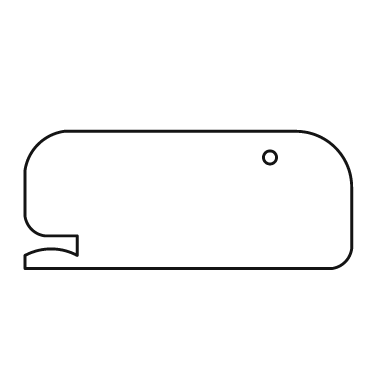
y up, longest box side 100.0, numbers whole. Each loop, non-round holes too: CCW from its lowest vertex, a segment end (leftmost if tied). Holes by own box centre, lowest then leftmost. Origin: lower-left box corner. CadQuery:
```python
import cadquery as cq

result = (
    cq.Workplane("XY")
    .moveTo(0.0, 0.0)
    .lineTo(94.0, 0.0)
    .threePointArc((98.0, 2.0), (100.0, 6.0))
    .lineTo(100.0, 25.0)
    .threePointArc((95.0, 37.0), (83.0, 42.0))
    .lineTo(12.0, 42.0)
    .threePointArc((4.0, 38.0), (0.0, 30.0))
    .lineTo(0.0, 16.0)
    .threePointArc((2.0, 12.0), (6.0, 10.0))
    .lineTo(16.0, 10.0)
    .lineTo(16.0, 4.0)
    .threePointArc((8.0, 6.0), (0.0, 4.0))
    .close()
    .moveTo(75.0, 34.0)
    .circle(2.0)
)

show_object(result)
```